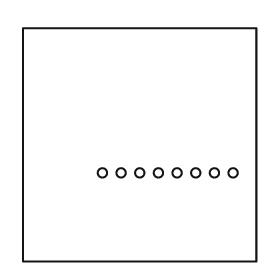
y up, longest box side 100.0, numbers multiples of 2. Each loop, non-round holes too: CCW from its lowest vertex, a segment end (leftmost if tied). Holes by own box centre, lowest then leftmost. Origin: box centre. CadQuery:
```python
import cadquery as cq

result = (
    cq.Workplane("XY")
    .moveTo(-50.0, -50.0)
    .lineTo(50.0, -50.0)
    .lineTo(50.0, 50.0)
    .lineTo(-50.0, 50.0)
    .close()
    .moveTo(-16.0, -12.0)
    .circle(2.0)
    .moveTo(-8.0, -12.0)
    .circle(2.0)
    .moveTo(0.0, -12.0)
    .circle(2.0)
    .moveTo(8.0, -12.0)
    .circle(2.0)
    .moveTo(16.0, -12.0)
    .circle(2.0)
    .moveTo(24.0, -12.0)
    .circle(2.0)
    .moveTo(32.0, -12.0)
    .circle(2.0)
    .moveTo(40.0, -12.0)
    .circle(2.0)
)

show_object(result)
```